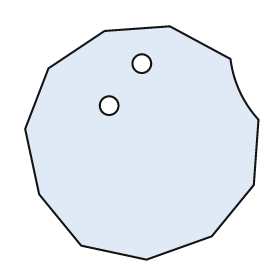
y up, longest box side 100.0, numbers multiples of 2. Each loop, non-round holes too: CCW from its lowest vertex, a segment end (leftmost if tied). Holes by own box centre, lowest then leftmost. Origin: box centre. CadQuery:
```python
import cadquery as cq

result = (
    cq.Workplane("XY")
    .moveTo(2.0, -50.0)
    .lineTo(30.0, -40.0)
    .lineTo(48.0, -18.0)
    .lineTo(50.0, 10.0)
    .threePointArc((42.0, 22.0), (38.0, 36.0))
    .lineTo(12.0, 50.0)
    .lineTo(-16.0, 48.0)
    .lineTo(-40.0, 32.0)
    .lineTo(-50.0, 6.0)
    .lineTo(-44.0, -22.0)
    .lineTo(-26.0, -44.0)
    .close()
    .moveTo(-14.0, 16.0)
    .circle(4.0)
    .moveTo(0.0, 34.0)
    .circle(4.0)
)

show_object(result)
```